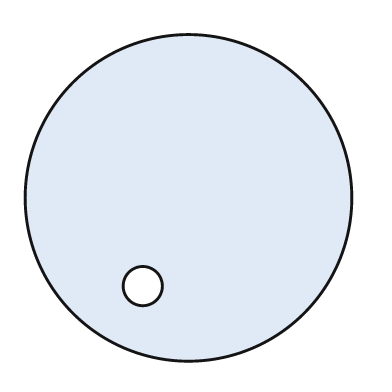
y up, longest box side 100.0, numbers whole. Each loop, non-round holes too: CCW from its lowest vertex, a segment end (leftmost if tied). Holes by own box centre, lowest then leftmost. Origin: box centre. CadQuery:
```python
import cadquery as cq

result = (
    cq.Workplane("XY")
    .moveTo(0.0, 0.0)
    .circle(50.0)
    .moveTo(-14.0, -27.0)
    .circle(6.0)
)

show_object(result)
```